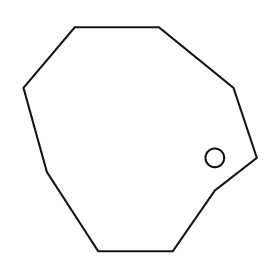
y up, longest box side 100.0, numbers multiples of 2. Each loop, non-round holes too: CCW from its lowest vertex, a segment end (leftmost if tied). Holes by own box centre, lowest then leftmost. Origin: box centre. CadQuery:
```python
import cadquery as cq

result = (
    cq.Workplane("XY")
    .moveTo(-18.0, -48.0)
    .lineTo(14.0, -48.0)
    .lineTo(32.0, -22.0)
    .lineTo(50.0, -8.0)
    .lineTo(40.0, 22.0)
    .lineTo(8.0, 48.0)
    .lineTo(-28.0, 48.0)
    .lineTo(-50.0, 22.0)
    .lineTo(-40.0, -14.0)
    .close()
    .moveTo(32.0, -8.0)
    .circle(4.0)
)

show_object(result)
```